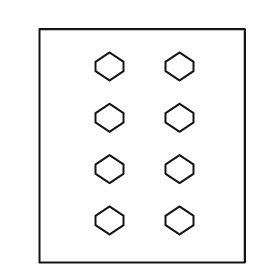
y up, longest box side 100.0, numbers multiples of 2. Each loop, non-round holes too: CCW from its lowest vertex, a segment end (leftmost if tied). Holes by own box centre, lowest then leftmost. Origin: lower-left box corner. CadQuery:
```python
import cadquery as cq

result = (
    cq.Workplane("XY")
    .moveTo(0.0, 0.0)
    .lineTo(88.0, 0.0)
    .lineTo(88.0, 100.0)
    .lineTo(0.0, 100.0)
    .close()
    .moveTo(30.0, 12.0)
    .lineTo(36.0, 16.0)
    .lineTo(36.0, 20.0)
    .lineTo(30.0, 24.0)
    .lineTo(24.0, 20.0)
    .lineTo(24.0, 16.0)
    .close()
    .moveTo(60.0, 12.0)
    .lineTo(66.0, 16.0)
    .lineTo(66.0, 20.0)
    .lineTo(60.0, 24.0)
    .lineTo(54.0, 20.0)
    .lineTo(54.0, 16.0)
    .close()
    .moveTo(30.0, 34.0)
    .lineTo(36.0, 38.0)
    .lineTo(36.0, 42.0)
    .lineTo(30.0, 46.0)
    .lineTo(24.0, 42.0)
    .lineTo(24.0, 38.0)
    .close()
    .moveTo(60.0, 34.0)
    .lineTo(66.0, 38.0)
    .lineTo(66.0, 42.0)
    .lineTo(60.0, 46.0)
    .lineTo(54.0, 42.0)
    .lineTo(54.0, 38.0)
    .close()
    .moveTo(30.0, 56.0)
    .lineTo(36.0, 60.0)
    .lineTo(36.0, 64.0)
    .lineTo(30.0, 68.0)
    .lineTo(24.0, 64.0)
    .lineTo(24.0, 60.0)
    .close()
    .moveTo(60.0, 56.0)
    .lineTo(66.0, 60.0)
    .lineTo(66.0, 64.0)
    .lineTo(60.0, 68.0)
    .lineTo(54.0, 64.0)
    .lineTo(54.0, 60.0)
    .close()
    .moveTo(30.0, 78.0)
    .lineTo(36.0, 82.0)
    .lineTo(36.0, 86.0)
    .lineTo(30.0, 90.0)
    .lineTo(24.0, 86.0)
    .lineTo(24.0, 82.0)
    .close()
    .moveTo(60.0, 78.0)
    .lineTo(66.0, 82.0)
    .lineTo(66.0, 86.0)
    .lineTo(60.0, 90.0)
    .lineTo(54.0, 86.0)
    .lineTo(54.0, 82.0)
    .close()
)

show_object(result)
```